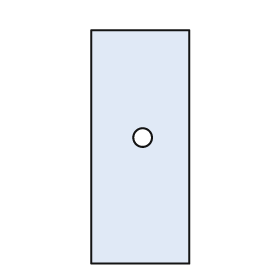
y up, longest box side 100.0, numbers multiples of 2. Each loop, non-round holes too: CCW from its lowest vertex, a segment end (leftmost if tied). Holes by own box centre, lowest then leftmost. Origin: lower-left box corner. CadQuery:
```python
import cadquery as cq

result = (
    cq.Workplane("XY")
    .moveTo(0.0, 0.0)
    .lineTo(42.0, 0.0)
    .lineTo(42.0, 100.0)
    .lineTo(0.0, 100.0)
    .close()
    .moveTo(22.0, 54.0)
    .circle(4.0)
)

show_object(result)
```